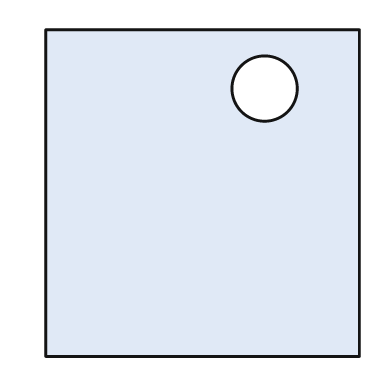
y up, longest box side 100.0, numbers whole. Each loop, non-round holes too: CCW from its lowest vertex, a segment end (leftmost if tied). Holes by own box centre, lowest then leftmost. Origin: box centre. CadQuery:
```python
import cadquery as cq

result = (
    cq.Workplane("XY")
    .moveTo(-48.0, -50.0)
    .lineTo(48.0, -50.0)
    .lineTo(48.0, 50.0)
    .lineTo(-48.0, 50.0)
    .close()
    .moveTo(19.0, 32.0)
    .circle(10.0)
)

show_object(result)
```